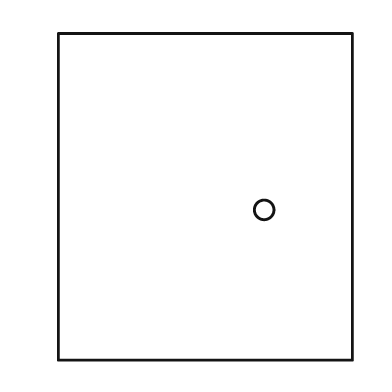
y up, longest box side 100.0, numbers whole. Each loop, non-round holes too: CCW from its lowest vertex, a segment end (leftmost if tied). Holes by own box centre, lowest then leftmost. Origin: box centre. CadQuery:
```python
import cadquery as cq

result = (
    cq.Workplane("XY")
    .moveTo(-45.0, -50.0)
    .lineTo(45.0, -50.0)
    .lineTo(45.0, 50.0)
    .lineTo(-45.0, 50.0)
    .close()
    .moveTo(18.0, -4.0)
    .circle(3.0)
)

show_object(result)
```